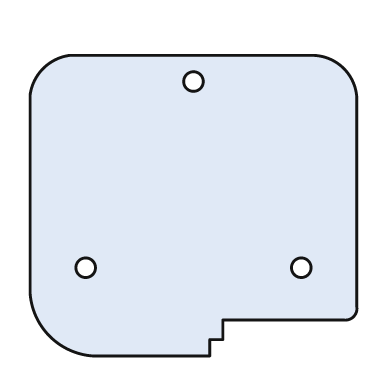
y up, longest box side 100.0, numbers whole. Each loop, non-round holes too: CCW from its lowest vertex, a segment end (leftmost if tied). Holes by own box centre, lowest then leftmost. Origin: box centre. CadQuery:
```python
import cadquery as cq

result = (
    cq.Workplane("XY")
    .moveTo(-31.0, -46.0)
    .lineTo(5.0, -46.0)
    .lineTo(5.0, -41.0)
    .lineTo(9.0, -41.0)
    .lineTo(9.0, -35.0)
    .lineTo(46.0, -35.0)
    .threePointArc((49.0, -34.0), (50.0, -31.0))
    .lineTo(50.0, 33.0)
    .threePointArc((46.0, 42.0), (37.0, 46.0))
    .lineTo(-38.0, 46.0)
    .threePointArc((-46.0, 42.0), (-50.0, 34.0))
    .lineTo(-50.0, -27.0)
    .threePointArc((-44.0, -40.0), (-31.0, -46.0))
    .close()
    .moveTo(-33.0, -19.0)
    .circle(3.0)
    .moveTo(33.0, -19.0)
    .circle(3.0)
    .moveTo(0.0, 38.0)
    .circle(3.0)
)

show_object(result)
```